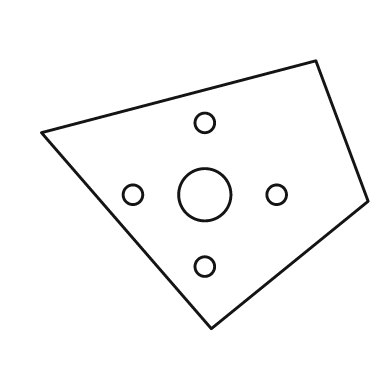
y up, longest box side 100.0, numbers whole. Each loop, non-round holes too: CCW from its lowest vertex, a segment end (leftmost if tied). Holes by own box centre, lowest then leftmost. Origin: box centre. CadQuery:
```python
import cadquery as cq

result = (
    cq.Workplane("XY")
    .moveTo(2.0, -41.0)
    .lineTo(50.0, -2.0)
    .lineTo(34.0, 41.0)
    .lineTo(-50.0, 19.0)
    .close()
    .moveTo(0.0, -22.0)
    .circle(3.0)
    .moveTo(-22.0, 0.0)
    .circle(3.0)
    .moveTo(0.0, 0.0)
    .circle(8.0)
    .moveTo(22.0, 0.0)
    .circle(3.0)
    .moveTo(0.0, 22.0)
    .circle(3.0)
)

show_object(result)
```